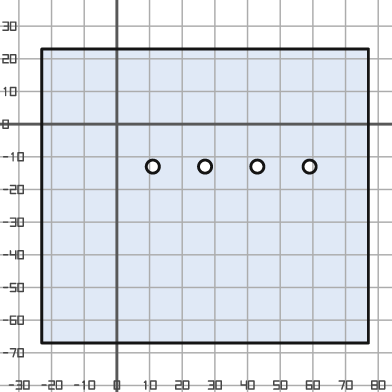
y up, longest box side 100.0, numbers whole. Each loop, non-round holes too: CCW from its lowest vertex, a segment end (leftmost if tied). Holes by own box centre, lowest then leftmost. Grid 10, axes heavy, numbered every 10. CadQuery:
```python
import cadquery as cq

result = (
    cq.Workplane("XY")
    .moveTo(-23.0, -67.0)
    .lineTo(77.0, -67.0)
    .lineTo(77.0, 23.0)
    .lineTo(-23.0, 23.0)
    .close()
    .moveTo(11.0, -13.0)
    .circle(2.0)
    .moveTo(27.0, -13.0)
    .circle(2.0)
    .moveTo(43.0, -13.0)
    .circle(2.0)
    .moveTo(59.0, -13.0)
    .circle(2.0)
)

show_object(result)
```